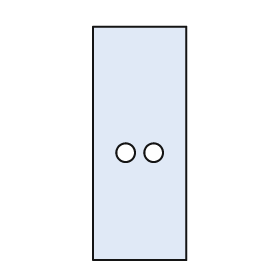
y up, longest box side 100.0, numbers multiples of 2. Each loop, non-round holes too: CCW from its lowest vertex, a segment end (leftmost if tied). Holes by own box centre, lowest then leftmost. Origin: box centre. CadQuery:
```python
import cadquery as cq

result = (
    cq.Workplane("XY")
    .moveTo(-20.0, -50.0)
    .lineTo(20.0, -50.0)
    .lineTo(20.0, 50.0)
    .lineTo(-20.0, 50.0)
    .close()
    .moveTo(-6.0, -4.0)
    .circle(4.0)
    .moveTo(6.0, -4.0)
    .circle(4.0)
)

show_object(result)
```